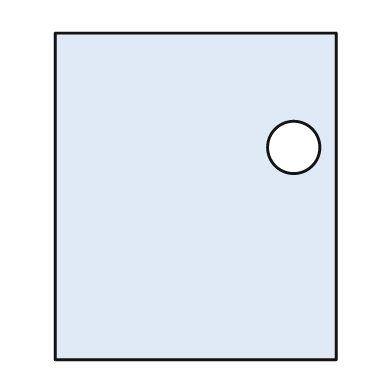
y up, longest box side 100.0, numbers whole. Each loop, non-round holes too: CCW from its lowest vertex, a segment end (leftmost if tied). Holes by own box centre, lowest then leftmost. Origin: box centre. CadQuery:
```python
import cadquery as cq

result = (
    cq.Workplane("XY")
    .moveTo(-43.0, -50.0)
    .lineTo(43.0, -50.0)
    .lineTo(43.0, 50.0)
    .lineTo(-43.0, 50.0)
    .close()
    .moveTo(30.0, 15.0)
    .circle(8.0)
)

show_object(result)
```